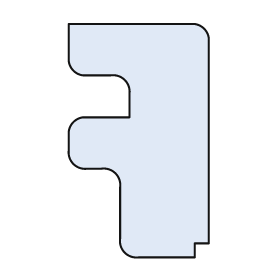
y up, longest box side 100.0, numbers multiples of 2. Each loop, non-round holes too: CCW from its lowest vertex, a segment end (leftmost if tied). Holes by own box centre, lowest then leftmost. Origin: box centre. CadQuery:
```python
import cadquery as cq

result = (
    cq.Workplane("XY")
    .moveTo(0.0, -50.0)
    .lineTo(24.0, -50.0)
    .lineTo(24.0, -44.0)
    .lineTo(30.0, -44.0)
    .lineTo(30.0, 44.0)
    .threePointArc((28.0, 48.0), (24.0, 50.0))
    .lineTo(-30.0, 50.0)
    .lineTo(-30.0, 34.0)
    .threePointArc((-28.0, 30.0), (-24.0, 28.0))
    .lineTo(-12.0, 28.0)
    .threePointArc((-6.0, 26.0), (-4.0, 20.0))
    .lineTo(-4.0, 10.0)
    .lineTo(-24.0, 10.0)
    .threePointArc((-28.0, 8.0), (-30.0, 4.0))
    .lineTo(-30.0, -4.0)
    .threePointArc((-28.0, -10.0), (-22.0, -12.0))
    .lineTo(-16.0, -12.0)
    .threePointArc((-10.0, -14.0), (-8.0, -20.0))
    .lineTo(-8.0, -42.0)
    .threePointArc((-6.0, -48.0), (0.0, -50.0))
    .close()
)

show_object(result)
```